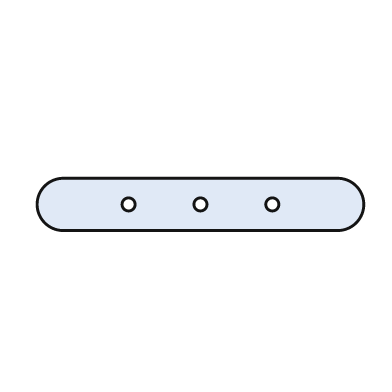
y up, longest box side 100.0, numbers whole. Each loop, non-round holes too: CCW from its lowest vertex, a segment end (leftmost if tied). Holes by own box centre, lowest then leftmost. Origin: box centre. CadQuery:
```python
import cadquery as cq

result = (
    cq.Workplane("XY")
    .moveTo(-42.0, -8.0)
    .lineTo(42.0, -8.0)
    .threePointArc((50.0, 0.0), (42.0, 8.0))
    .lineTo(-42.0, 8.0)
    .threePointArc((-50.0, 0.0), (-42.0, -8.0))
    .close()
    .moveTo(-22.0, 0.0)
    .circle(2.0)
    .moveTo(0.0, 0.0)
    .circle(2.0)
    .moveTo(22.0, 0.0)
    .circle(2.0)
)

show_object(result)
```